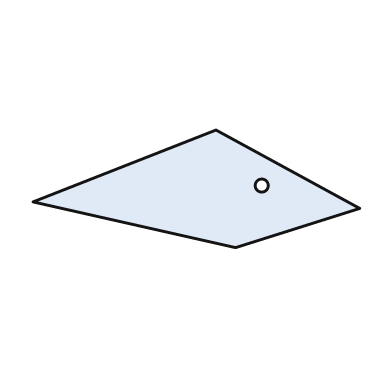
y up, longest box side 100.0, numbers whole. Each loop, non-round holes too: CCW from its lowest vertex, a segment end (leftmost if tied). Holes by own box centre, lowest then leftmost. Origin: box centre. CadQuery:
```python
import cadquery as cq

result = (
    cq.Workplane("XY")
    .moveTo(12.0, -18.0)
    .lineTo(50.0, -6.0)
    .lineTo(6.0, 18.0)
    .lineTo(-50.0, -4.0)
    .close()
    .moveTo(20.0, 1.0)
    .circle(2.0)
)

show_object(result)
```